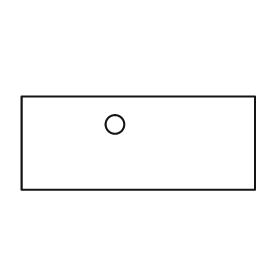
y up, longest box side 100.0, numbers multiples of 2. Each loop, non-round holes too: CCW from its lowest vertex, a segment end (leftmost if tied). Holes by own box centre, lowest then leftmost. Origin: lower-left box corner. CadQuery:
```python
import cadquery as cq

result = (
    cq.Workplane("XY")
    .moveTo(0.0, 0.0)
    .lineTo(100.0, 0.0)
    .lineTo(100.0, 40.0)
    .lineTo(0.0, 40.0)
    .close()
    .moveTo(40.0, 28.0)
    .circle(4.0)
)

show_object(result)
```